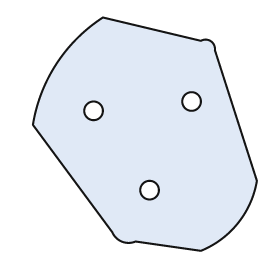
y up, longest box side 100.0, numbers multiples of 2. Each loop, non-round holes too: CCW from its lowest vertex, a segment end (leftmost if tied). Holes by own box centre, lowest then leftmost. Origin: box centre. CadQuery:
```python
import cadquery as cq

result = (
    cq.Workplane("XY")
    .moveTo(24.0, -50.0)
    .threePointArc((40.0, -38.0), (48.0, -20.0))
    .lineTo(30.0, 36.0)
    .threePointArc((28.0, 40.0), (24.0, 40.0))
    .lineTo(-18.0, 50.0)
    .threePointArc((-38.0, 30.0), (-48.0, 4.0))
    .lineTo(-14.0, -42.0)
    .threePointArc((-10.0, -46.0), (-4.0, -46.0))
    .close()
    .moveTo(2.0, -24.0)
    .circle(4.0)
    .moveTo(-22.0, 10.0)
    .circle(4.0)
    .moveTo(20.0, 14.0)
    .circle(4.0)
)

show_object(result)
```